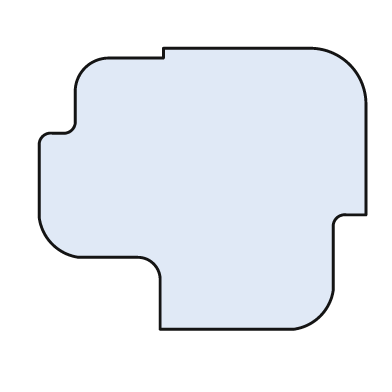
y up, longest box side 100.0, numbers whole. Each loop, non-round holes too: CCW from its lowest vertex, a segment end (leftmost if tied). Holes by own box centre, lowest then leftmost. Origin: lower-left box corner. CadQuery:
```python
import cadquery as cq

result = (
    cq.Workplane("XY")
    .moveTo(37.0, 0.0)
    .lineTo(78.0, 0.0)
    .threePointArc((86.0, 4.0), (90.0, 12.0))
    .lineTo(90.0, 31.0)
    .threePointArc((91.0, 34.0), (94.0, 35.0))
    .lineTo(100.0, 35.0)
    .lineTo(100.0, 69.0)
    .threePointArc((95.0, 81.0), (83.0, 86.0))
    .lineTo(38.0, 86.0)
    .lineTo(38.0, 83.0)
    .lineTo(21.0, 83.0)
    .threePointArc((14.0, 80.0), (11.0, 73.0))
    .lineTo(11.0, 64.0)
    .threePointArc((10.0, 61.0), (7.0, 60.0))
    .lineTo(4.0, 60.0)
    .threePointArc((1.0, 59.0), (0.0, 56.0))
    .lineTo(0.0, 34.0)
    .threePointArc((4.0, 26.0), (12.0, 22.0))
    .lineTo(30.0, 22.0)
    .threePointArc((35.0, 20.0), (37.0, 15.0))
    .close()
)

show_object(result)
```